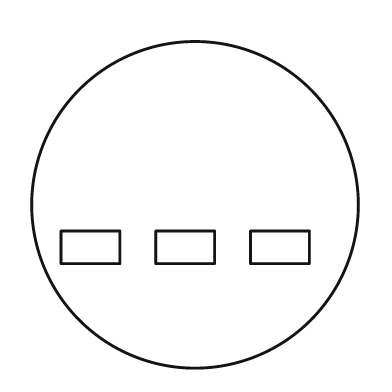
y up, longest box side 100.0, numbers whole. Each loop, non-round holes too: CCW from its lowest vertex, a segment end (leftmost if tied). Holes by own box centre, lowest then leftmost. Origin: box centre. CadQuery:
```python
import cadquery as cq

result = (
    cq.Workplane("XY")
    .moveTo(0.0, 0.0)
    .circle(50.0)
    .moveTo(-41.0, -18.0)
    .lineTo(-23.0, -18.0)
    .lineTo(-23.0, -8.0)
    .lineTo(-41.0, -8.0)
    .close()
    .moveTo(-12.0, -18.0)
    .lineTo(6.0, -18.0)
    .lineTo(6.0, -8.0)
    .lineTo(-12.0, -8.0)
    .close()
    .moveTo(17.0, -18.0)
    .lineTo(35.0, -18.0)
    .lineTo(35.0, -8.0)
    .lineTo(17.0, -8.0)
    .close()
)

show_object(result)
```